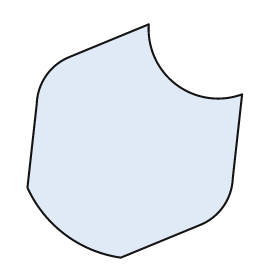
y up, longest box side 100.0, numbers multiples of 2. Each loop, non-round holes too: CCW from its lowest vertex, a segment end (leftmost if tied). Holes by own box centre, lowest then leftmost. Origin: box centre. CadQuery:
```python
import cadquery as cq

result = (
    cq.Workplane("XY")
    .moveTo(-6.0, -50.0)
    .lineTo(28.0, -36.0)
    .threePointArc((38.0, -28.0), (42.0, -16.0))
    .lineTo(46.0, 20.0)
    .threePointArc((18.0, 24.0), (6.0, 50.0))
    .lineTo(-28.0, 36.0)
    .threePointArc((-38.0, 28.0), (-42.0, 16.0))
    .lineTo(-46.0, -20.0)
    .threePointArc((-30.0, -40.0), (-6.0, -50.0))
    .close()
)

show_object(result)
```